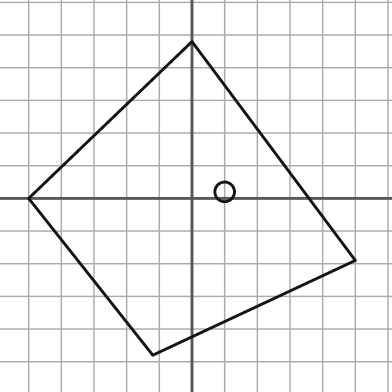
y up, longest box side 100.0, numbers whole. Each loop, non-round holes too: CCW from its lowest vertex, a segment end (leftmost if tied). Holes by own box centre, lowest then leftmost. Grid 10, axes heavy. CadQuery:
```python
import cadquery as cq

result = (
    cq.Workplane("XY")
    .moveTo(-12.0, -48.0)
    .lineTo(50.0, -19.0)
    .lineTo(0.0, 48.0)
    .lineTo(-50.0, 0.0)
    .close()
    .moveTo(10.0, 2.0)
    .circle(3.0)
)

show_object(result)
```